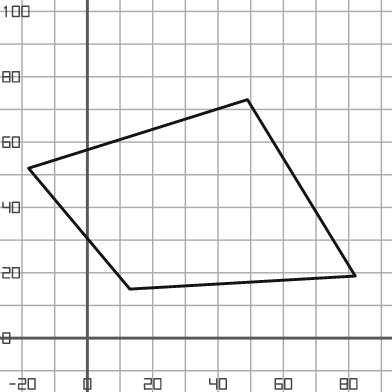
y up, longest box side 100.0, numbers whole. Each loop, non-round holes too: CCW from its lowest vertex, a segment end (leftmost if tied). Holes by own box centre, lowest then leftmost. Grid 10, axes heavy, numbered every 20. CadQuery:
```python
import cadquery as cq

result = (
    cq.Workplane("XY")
    .moveTo(13.0, 15.0)
    .lineTo(82.0, 19.0)
    .lineTo(49.0, 73.0)
    .lineTo(-18.0, 52.0)
    .close()
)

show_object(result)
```